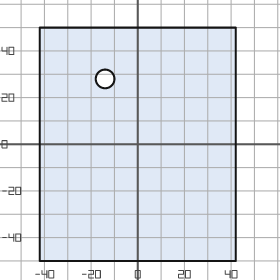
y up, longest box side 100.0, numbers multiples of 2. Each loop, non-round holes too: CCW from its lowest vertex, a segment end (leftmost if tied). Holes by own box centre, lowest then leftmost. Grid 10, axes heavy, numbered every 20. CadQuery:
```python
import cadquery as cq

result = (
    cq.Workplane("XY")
    .moveTo(-42.0, -50.0)
    .lineTo(42.0, -50.0)
    .lineTo(42.0, 50.0)
    .lineTo(-42.0, 50.0)
    .close()
    .moveTo(-14.0, 28.0)
    .circle(4.0)
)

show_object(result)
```